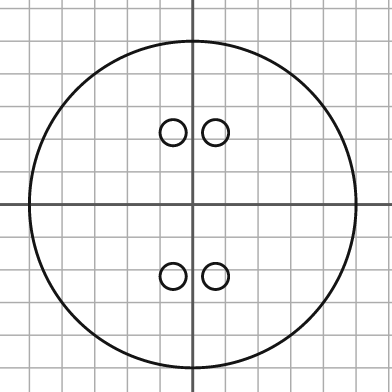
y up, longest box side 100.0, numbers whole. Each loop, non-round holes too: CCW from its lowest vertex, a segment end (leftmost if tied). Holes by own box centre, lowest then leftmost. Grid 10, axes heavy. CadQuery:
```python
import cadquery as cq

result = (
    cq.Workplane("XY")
    .moveTo(0.0, 0.0)
    .circle(50.0)
    .moveTo(-6.0, -22.0)
    .circle(4.0)
    .moveTo(7.0, -22.0)
    .circle(4.0)
    .moveTo(-6.0, 22.0)
    .circle(4.0)
    .moveTo(7.0, 22.0)
    .circle(4.0)
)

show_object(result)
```